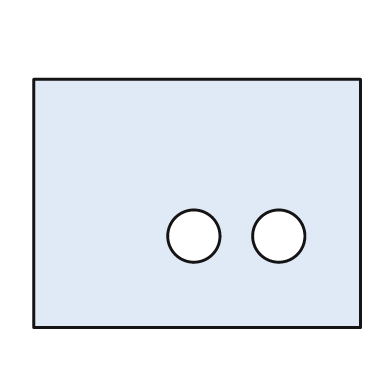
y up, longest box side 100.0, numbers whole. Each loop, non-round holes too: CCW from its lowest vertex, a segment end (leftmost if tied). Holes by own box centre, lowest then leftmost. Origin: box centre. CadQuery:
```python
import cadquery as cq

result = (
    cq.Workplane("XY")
    .moveTo(-50.0, -38.0)
    .lineTo(50.0, -38.0)
    .lineTo(50.0, 38.0)
    .lineTo(-50.0, 38.0)
    .close()
    .moveTo(-1.0, -10.0)
    .circle(8.0)
    .moveTo(25.0, -10.0)
    .circle(8.0)
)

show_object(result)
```